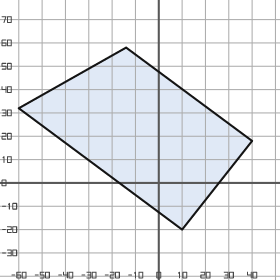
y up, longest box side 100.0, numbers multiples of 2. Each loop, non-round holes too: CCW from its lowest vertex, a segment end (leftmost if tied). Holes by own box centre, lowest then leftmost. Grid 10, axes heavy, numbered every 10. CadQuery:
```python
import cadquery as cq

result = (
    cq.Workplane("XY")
    .moveTo(10.0, -20.0)
    .lineTo(40.0, 18.0)
    .lineTo(-14.0, 58.0)
    .lineTo(-60.0, 32.0)
    .close()
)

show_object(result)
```